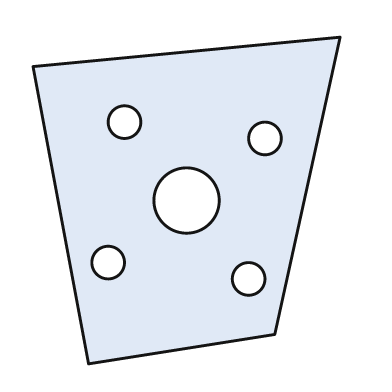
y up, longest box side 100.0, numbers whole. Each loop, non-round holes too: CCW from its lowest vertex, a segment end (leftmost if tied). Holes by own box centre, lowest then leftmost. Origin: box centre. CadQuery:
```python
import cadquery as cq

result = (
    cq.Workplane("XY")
    .moveTo(-30.0, -50.0)
    .lineTo(27.0, -41.0)
    .lineTo(47.0, 50.0)
    .lineTo(-47.0, 41.0)
    .close()
    .moveTo(19.0, -24.0)
    .circle(5.0)
    .moveTo(-24.0, -19.0)
    .circle(5.0)
    .moveTo(0.0, 0.0)
    .circle(10.0)
    .moveTo(24.0, 19.0)
    .circle(5.0)
    .moveTo(-19.0, 24.0)
    .circle(5.0)
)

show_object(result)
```